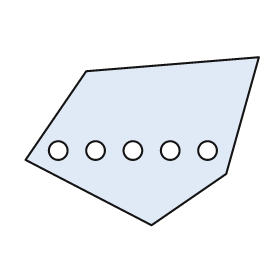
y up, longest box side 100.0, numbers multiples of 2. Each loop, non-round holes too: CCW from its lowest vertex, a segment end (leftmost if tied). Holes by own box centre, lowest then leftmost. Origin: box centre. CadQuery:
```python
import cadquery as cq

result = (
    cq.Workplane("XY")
    .moveTo(4.0, -36.0)
    .lineTo(36.0, -14.0)
    .lineTo(50.0, 36.0)
    .lineTo(-24.0, 30.0)
    .lineTo(-50.0, -8.0)
    .close()
    .moveTo(-36.0, -4.0)
    .circle(4.0)
    .moveTo(-20.0, -4.0)
    .circle(4.0)
    .moveTo(-4.0, -4.0)
    .circle(4.0)
    .moveTo(12.0, -4.0)
    .circle(4.0)
    .moveTo(28.0, -4.0)
    .circle(4.0)
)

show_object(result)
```